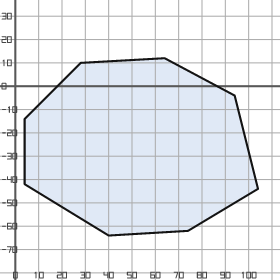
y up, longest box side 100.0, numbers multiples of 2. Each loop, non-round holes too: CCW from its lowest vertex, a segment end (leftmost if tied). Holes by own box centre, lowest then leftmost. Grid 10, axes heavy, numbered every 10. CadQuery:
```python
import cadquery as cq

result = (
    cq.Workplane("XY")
    .moveTo(40.0, -64.0)
    .lineTo(74.0, -62.0)
    .lineTo(104.0, -44.0)
    .lineTo(94.0, -4.0)
    .lineTo(64.0, 12.0)
    .lineTo(28.0, 10.0)
    .lineTo(4.0, -14.0)
    .lineTo(4.0, -42.0)
    .close()
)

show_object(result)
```